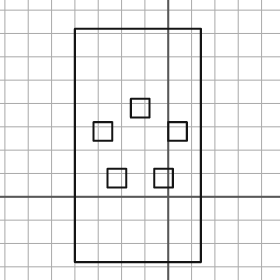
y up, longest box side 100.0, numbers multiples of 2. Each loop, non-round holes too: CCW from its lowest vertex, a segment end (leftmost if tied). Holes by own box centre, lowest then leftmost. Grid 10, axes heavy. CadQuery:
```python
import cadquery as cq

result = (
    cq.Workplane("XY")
    .moveTo(-40.0, -28.0)
    .lineTo(14.0, -28.0)
    .lineTo(14.0, 72.0)
    .lineTo(-40.0, 72.0)
    .close()
    .moveTo(-26.0, 4.0)
    .lineTo(-18.0, 4.0)
    .lineTo(-18.0, 12.0)
    .lineTo(-26.0, 12.0)
    .close()
    .moveTo(-6.0, 4.0)
    .lineTo(2.0, 4.0)
    .lineTo(2.0, 12.0)
    .lineTo(-6.0, 12.0)
    .close()
    .moveTo(-32.0, 24.0)
    .lineTo(-24.0, 24.0)
    .lineTo(-24.0, 32.0)
    .lineTo(-32.0, 32.0)
    .close()
    .moveTo(0.0, 24.0)
    .lineTo(8.0, 24.0)
    .lineTo(8.0, 32.0)
    .lineTo(0.0, 32.0)
    .close()
    .moveTo(-16.0, 34.0)
    .lineTo(-8.0, 34.0)
    .lineTo(-8.0, 42.0)
    .lineTo(-16.0, 42.0)
    .close()
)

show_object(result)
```